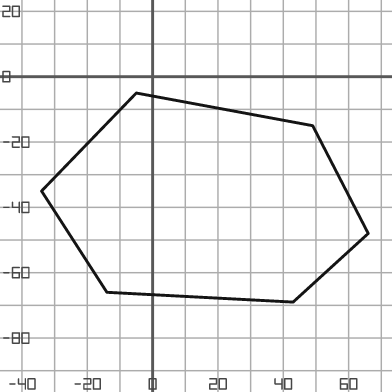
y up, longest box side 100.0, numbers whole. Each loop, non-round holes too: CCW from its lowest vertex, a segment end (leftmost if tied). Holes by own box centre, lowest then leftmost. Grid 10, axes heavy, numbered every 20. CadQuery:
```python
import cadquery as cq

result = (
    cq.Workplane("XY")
    .moveTo(43.0, -69.0)
    .lineTo(66.0, -48.0)
    .lineTo(49.0, -15.0)
    .lineTo(-5.0, -5.0)
    .lineTo(-34.0, -35.0)
    .lineTo(-14.0, -66.0)
    .close()
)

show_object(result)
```